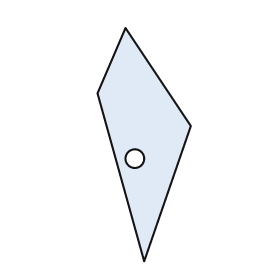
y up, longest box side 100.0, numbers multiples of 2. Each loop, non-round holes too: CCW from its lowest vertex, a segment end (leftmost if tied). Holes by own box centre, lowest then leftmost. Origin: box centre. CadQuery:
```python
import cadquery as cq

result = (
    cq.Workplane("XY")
    .moveTo(0.0, -50.0)
    .lineTo(20.0, 8.0)
    .lineTo(-8.0, 50.0)
    .lineTo(-20.0, 22.0)
    .close()
    .moveTo(-4.0, -6.0)
    .circle(4.0)
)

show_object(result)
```